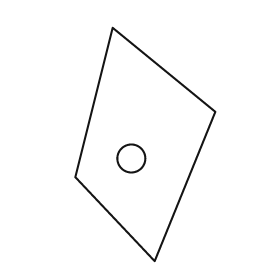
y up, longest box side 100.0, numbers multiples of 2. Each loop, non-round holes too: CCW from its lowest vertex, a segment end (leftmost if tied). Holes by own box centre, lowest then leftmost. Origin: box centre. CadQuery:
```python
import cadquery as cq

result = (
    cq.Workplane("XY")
    .moveTo(4.0, -50.0)
    .lineTo(30.0, 14.0)
    .lineTo(-14.0, 50.0)
    .lineTo(-30.0, -14.0)
    .close()
    .moveTo(-6.0, -6.0)
    .circle(6.0)
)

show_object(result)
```